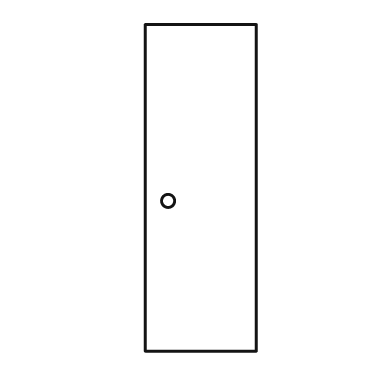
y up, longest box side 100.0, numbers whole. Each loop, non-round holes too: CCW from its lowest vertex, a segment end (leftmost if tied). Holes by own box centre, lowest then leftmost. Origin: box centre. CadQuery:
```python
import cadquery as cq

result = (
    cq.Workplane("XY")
    .moveTo(-17.0, -50.0)
    .lineTo(17.0, -50.0)
    .lineTo(17.0, 50.0)
    .lineTo(-17.0, 50.0)
    .close()
    .moveTo(-10.0, -4.0)
    .circle(2.0)
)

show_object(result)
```